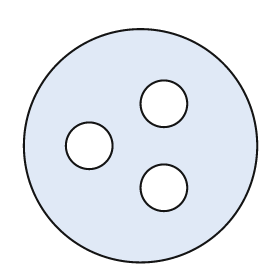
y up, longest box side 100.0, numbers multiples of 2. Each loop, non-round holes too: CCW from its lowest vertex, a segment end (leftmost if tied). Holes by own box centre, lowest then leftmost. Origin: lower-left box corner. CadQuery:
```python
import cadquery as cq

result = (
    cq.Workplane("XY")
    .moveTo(50.0, 50.0)
    .circle(50.0)
    .moveTo(60.0, 32.0)
    .circle(10.0)
    .moveTo(28.0, 50.0)
    .circle(10.0)
    .moveTo(60.0, 68.0)
    .circle(10.0)
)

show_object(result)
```